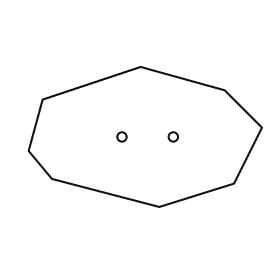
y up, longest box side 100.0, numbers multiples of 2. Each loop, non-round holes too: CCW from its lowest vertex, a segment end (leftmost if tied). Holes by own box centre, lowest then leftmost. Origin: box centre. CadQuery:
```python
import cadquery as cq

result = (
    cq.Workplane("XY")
    .moveTo(6.0, -30.0)
    .lineTo(38.0, -20.0)
    .lineTo(50.0, 4.0)
    .lineTo(34.0, 20.0)
    .lineTo(-2.0, 30.0)
    .lineTo(-44.0, 16.0)
    .lineTo(-50.0, -6.0)
    .lineTo(-40.0, -18.0)
    .close()
    .moveTo(-10.0, 0.0)
    .circle(2.0)
    .moveTo(12.0, 0.0)
    .circle(2.0)
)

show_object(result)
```